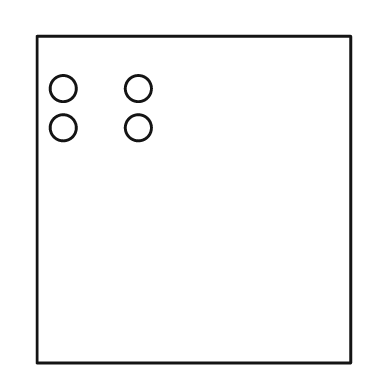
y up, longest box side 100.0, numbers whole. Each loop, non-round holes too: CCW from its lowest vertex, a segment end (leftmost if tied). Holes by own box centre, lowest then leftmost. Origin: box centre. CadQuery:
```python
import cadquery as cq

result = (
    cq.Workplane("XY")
    .moveTo(-48.0, -50.0)
    .lineTo(48.0, -50.0)
    .lineTo(48.0, 50.0)
    .lineTo(-48.0, 50.0)
    .close()
    .moveTo(-40.0, 22.0)
    .circle(4.0)
    .moveTo(-17.0, 22.0)
    .circle(4.0)
    .moveTo(-40.0, 34.0)
    .circle(4.0)
    .moveTo(-17.0, 34.0)
    .circle(4.0)
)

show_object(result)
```